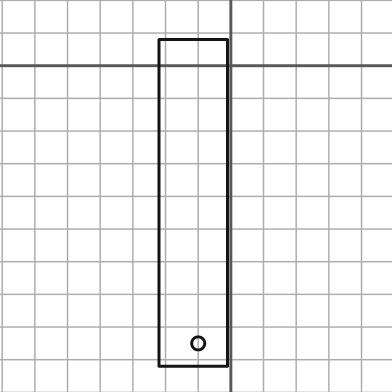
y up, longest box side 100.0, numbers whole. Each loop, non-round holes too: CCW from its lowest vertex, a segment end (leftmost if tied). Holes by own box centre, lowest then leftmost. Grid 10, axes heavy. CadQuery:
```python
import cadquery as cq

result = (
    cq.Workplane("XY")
    .moveTo(-22.0, -92.0)
    .lineTo(-1.0, -92.0)
    .lineTo(-1.0, 8.0)
    .lineTo(-22.0, 8.0)
    .close()
    .moveTo(-10.0, -85.0)
    .circle(2.0)
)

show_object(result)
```